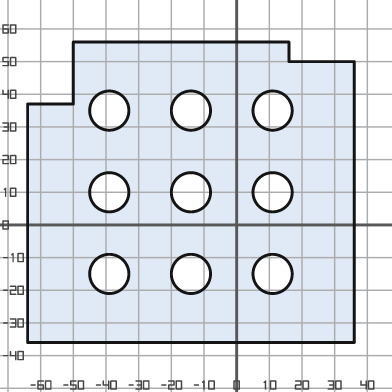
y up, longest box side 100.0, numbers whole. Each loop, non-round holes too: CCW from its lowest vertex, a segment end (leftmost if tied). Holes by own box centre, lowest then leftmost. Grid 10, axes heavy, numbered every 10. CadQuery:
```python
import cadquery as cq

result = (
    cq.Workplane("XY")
    .moveTo(-64.0, -36.0)
    .lineTo(36.0, -36.0)
    .lineTo(36.0, 50.0)
    .lineTo(16.0, 50.0)
    .lineTo(16.0, 56.0)
    .lineTo(-50.0, 56.0)
    .lineTo(-50.0, 37.0)
    .lineTo(-64.0, 37.0)
    .close()
    .moveTo(-39.0, -15.0)
    .circle(6.0)
    .moveTo(-14.0, -15.0)
    .circle(6.0)
    .moveTo(11.0, -15.0)
    .circle(6.0)
    .moveTo(-39.0, 10.0)
    .circle(6.0)
    .moveTo(-14.0, 10.0)
    .circle(6.0)
    .moveTo(11.0, 10.0)
    .circle(6.0)
    .moveTo(-39.0, 35.0)
    .circle(6.0)
    .moveTo(-14.0, 35.0)
    .circle(6.0)
    .moveTo(11.0, 35.0)
    .circle(6.0)
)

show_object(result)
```